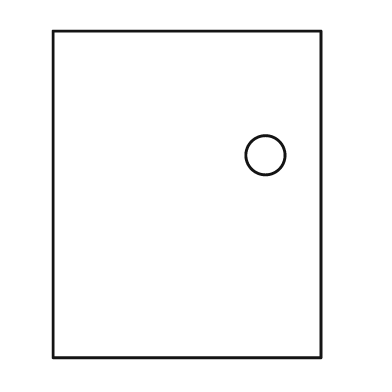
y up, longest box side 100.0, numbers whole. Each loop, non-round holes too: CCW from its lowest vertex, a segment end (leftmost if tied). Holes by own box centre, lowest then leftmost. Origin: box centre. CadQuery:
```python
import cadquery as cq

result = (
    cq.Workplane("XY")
    .moveTo(-41.0, -50.0)
    .lineTo(41.0, -50.0)
    .lineTo(41.0, 50.0)
    .lineTo(-41.0, 50.0)
    .close()
    .moveTo(24.0, 12.0)
    .circle(6.0)
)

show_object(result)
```